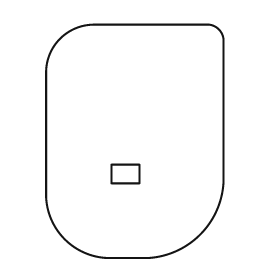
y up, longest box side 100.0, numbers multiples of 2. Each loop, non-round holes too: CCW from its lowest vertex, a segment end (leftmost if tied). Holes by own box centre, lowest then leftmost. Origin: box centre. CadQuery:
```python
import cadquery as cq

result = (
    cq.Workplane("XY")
    .moveTo(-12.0, -50.0)
    .lineTo(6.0, -50.0)
    .threePointArc((28.0, -40.0), (38.0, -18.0))
    .lineTo(38.0, 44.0)
    .threePointArc((36.0, 48.0), (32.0, 50.0))
    .lineTo(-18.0, 50.0)
    .threePointArc((-32.0, 44.0), (-38.0, 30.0))
    .lineTo(-38.0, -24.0)
    .threePointArc((-30.0, -42.0), (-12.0, -50.0))
    .close()
    .moveTo(-10.0, -18.0)
    .lineTo(2.0, -18.0)
    .lineTo(2.0, -10.0)
    .lineTo(-10.0, -10.0)
    .close()
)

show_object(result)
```